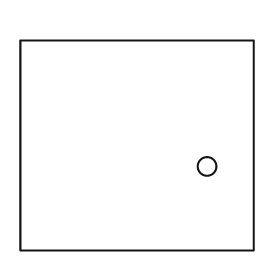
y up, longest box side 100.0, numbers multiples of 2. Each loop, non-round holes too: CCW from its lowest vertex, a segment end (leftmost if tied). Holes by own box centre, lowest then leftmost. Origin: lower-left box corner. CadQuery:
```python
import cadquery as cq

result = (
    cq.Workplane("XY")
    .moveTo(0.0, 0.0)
    .lineTo(100.0, 0.0)
    .lineTo(100.0, 90.0)
    .lineTo(0.0, 90.0)
    .close()
    .moveTo(80.0, 36.0)
    .circle(4.0)
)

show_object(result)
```